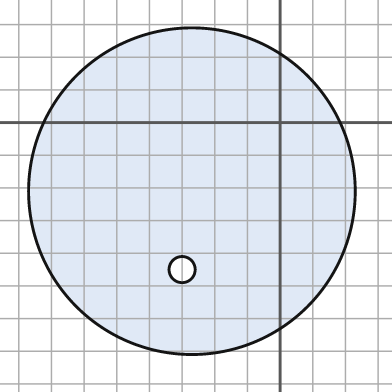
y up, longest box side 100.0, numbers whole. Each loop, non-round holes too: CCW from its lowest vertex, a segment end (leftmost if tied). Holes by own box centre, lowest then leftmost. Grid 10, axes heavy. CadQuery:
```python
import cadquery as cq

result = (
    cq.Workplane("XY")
    .moveTo(-27.0, -21.0)
    .circle(50.0)
    .moveTo(-30.0, -45.0)
    .circle(4.0)
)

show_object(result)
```